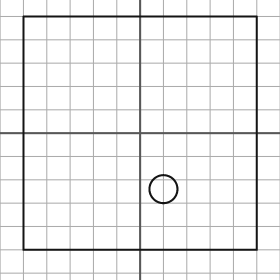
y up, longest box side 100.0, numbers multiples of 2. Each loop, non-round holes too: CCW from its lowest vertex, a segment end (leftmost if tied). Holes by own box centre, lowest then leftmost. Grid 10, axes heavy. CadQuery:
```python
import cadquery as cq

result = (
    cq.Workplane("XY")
    .moveTo(-50.0, -50.0)
    .lineTo(50.0, -50.0)
    .lineTo(50.0, 50.0)
    .lineTo(-50.0, 50.0)
    .close()
    .moveTo(10.0, -24.0)
    .circle(6.0)
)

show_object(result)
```